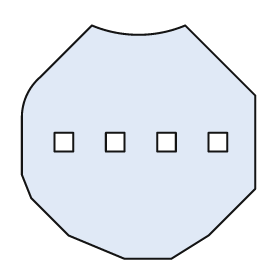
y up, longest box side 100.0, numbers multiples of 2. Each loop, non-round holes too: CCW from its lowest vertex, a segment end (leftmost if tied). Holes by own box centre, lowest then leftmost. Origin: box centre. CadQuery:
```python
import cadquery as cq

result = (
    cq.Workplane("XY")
    .moveTo(-6.0, -50.0)
    .lineTo(14.0, -50.0)
    .lineTo(30.0, -40.0)
    .lineTo(50.0, -20.0)
    .lineTo(50.0, 20.0)
    .lineTo(20.0, 50.0)
    .threePointArc((0.0, 46.0), (-20.0, 50.0))
    .lineTo(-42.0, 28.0)
    .threePointArc((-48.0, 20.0), (-50.0, 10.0))
    .lineTo(-50.0, -14.0)
    .lineTo(-46.0, -24.0)
    .lineTo(-30.0, -40.0)
    .close()
    .moveTo(-36.0, -4.0)
    .lineTo(-28.0, -4.0)
    .lineTo(-28.0, 4.0)
    .lineTo(-36.0, 4.0)
    .close()
    .moveTo(-14.0, -4.0)
    .lineTo(-6.0, -4.0)
    .lineTo(-6.0, 4.0)
    .lineTo(-14.0, 4.0)
    .close()
    .moveTo(8.0, -4.0)
    .lineTo(16.0, -4.0)
    .lineTo(16.0, 4.0)
    .lineTo(8.0, 4.0)
    .close()
    .moveTo(30.0, -4.0)
    .lineTo(38.0, -4.0)
    .lineTo(38.0, 4.0)
    .lineTo(30.0, 4.0)
    .close()
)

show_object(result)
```